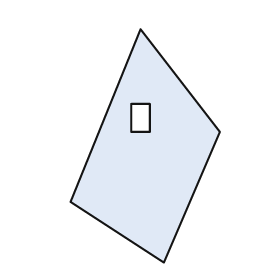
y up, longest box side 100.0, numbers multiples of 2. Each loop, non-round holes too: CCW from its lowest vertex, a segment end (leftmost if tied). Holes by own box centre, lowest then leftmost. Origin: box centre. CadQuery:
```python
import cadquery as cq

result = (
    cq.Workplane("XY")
    .moveTo(8.0, -50.0)
    .lineTo(32.0, 6.0)
    .lineTo(-2.0, 50.0)
    .lineTo(-32.0, -24.0)
    .close()
    .moveTo(-6.0, 6.0)
    .lineTo(2.0, 6.0)
    .lineTo(2.0, 18.0)
    .lineTo(-6.0, 18.0)
    .close()
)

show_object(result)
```